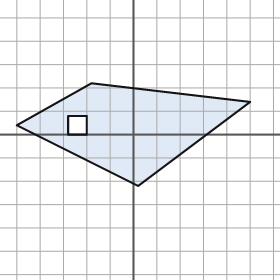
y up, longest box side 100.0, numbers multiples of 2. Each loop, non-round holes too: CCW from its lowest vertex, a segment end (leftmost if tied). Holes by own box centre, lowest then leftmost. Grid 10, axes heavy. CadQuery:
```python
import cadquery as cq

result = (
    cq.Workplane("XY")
    .moveTo(2.0, -22.0)
    .lineTo(50.0, 14.0)
    .lineTo(-18.0, 22.0)
    .lineTo(-50.0, 4.0)
    .close()
    .moveTo(-28.0, 0.0)
    .lineTo(-20.0, 0.0)
    .lineTo(-20.0, 8.0)
    .lineTo(-28.0, 8.0)
    .close()
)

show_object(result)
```